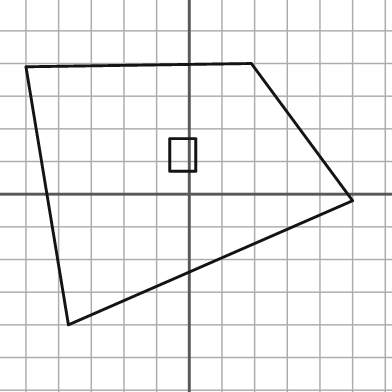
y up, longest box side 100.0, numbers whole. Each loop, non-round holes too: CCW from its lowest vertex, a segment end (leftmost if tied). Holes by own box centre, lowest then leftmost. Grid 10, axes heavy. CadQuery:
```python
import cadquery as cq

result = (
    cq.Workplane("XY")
    .moveTo(-37.0, -40.0)
    .lineTo(50.0, -2.0)
    .lineTo(19.0, 40.0)
    .lineTo(-50.0, 39.0)
    .close()
    .moveTo(-6.0, 7.0)
    .lineTo(2.0, 7.0)
    .lineTo(2.0, 17.0)
    .lineTo(-6.0, 17.0)
    .close()
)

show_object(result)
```